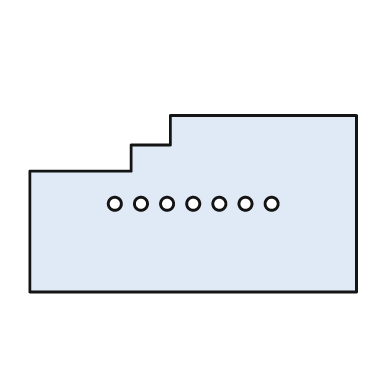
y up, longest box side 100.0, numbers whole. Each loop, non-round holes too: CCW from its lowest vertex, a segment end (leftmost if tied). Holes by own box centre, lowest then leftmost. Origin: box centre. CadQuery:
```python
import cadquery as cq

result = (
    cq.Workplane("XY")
    .moveTo(-50.0, -27.0)
    .lineTo(50.0, -27.0)
    .lineTo(50.0, 27.0)
    .lineTo(-7.0, 27.0)
    .lineTo(-7.0, 18.0)
    .lineTo(-19.0, 18.0)
    .lineTo(-19.0, 10.0)
    .lineTo(-50.0, 10.0)
    .close()
    .moveTo(-24.0, 0.0)
    .circle(2.0)
    .moveTo(-16.0, 0.0)
    .circle(2.0)
    .moveTo(-8.0, 0.0)
    .circle(2.0)
    .moveTo(0.0, 0.0)
    .circle(2.0)
    .moveTo(8.0, 0.0)
    .circle(2.0)
    .moveTo(16.0, 0.0)
    .circle(2.0)
    .moveTo(24.0, 0.0)
    .circle(2.0)
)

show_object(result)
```